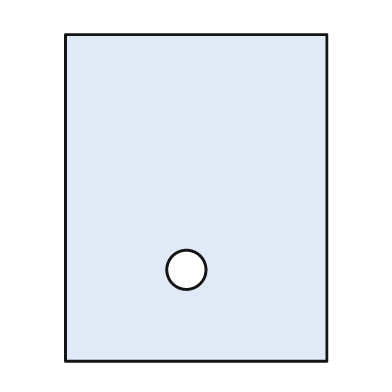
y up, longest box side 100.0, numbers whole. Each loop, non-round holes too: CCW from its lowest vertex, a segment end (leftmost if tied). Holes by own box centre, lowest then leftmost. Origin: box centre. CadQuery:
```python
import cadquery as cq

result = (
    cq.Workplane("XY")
    .moveTo(-40.0, -50.0)
    .lineTo(40.0, -50.0)
    .lineTo(40.0, 50.0)
    .lineTo(-40.0, 50.0)
    .close()
    .moveTo(-3.0, -22.0)
    .circle(6.0)
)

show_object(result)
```